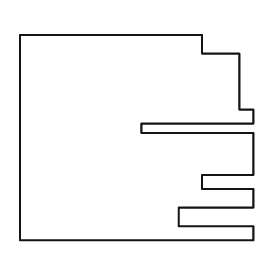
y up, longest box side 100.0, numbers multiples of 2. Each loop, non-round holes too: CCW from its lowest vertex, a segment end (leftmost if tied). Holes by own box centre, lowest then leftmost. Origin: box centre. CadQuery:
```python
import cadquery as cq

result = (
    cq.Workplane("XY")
    .moveTo(-50.0, -44.0)
    .lineTo(50.0, -44.0)
    .lineTo(50.0, -38.0)
    .lineTo(18.0, -38.0)
    .lineTo(18.0, -30.0)
    .lineTo(50.0, -30.0)
    .lineTo(50.0, -22.0)
    .lineTo(28.0, -22.0)
    .lineTo(28.0, -16.0)
    .lineTo(50.0, -16.0)
    .lineTo(50.0, 2.0)
    .lineTo(2.0, 2.0)
    .lineTo(2.0, 6.0)
    .lineTo(50.0, 6.0)
    .lineTo(50.0, 12.0)
    .lineTo(44.0, 12.0)
    .lineTo(44.0, 36.0)
    .lineTo(28.0, 36.0)
    .lineTo(28.0, 44.0)
    .lineTo(-50.0, 44.0)
    .close()
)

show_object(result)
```